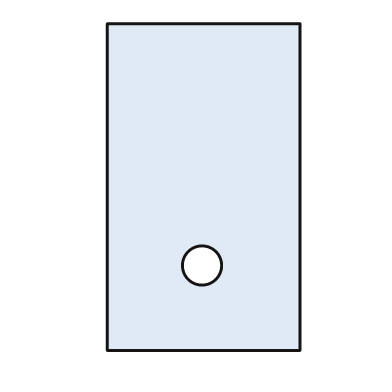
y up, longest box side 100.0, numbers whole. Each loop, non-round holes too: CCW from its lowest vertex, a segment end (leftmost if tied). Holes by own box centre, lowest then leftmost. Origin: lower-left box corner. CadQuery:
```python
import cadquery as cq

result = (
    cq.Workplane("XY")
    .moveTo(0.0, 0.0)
    .lineTo(59.0, 0.0)
    .lineTo(59.0, 100.0)
    .lineTo(0.0, 100.0)
    .close()
    .moveTo(29.0, 26.0)
    .circle(6.0)
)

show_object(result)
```